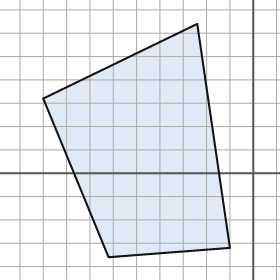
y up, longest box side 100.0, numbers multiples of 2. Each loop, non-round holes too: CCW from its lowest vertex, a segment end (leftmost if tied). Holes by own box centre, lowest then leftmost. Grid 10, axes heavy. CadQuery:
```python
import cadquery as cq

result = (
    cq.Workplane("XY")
    .moveTo(-62.0, -36.0)
    .lineTo(-10.0, -32.0)
    .lineTo(-24.0, 64.0)
    .lineTo(-90.0, 32.0)
    .close()
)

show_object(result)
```